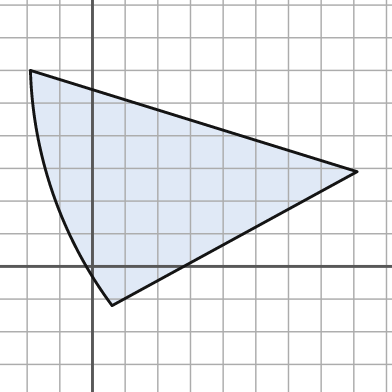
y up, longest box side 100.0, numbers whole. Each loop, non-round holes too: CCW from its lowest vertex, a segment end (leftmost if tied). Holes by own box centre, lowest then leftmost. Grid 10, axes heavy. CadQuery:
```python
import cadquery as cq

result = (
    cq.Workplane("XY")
    .moveTo(6.0, -12.0)
    .lineTo(81.0, 29.0)
    .lineTo(-19.0, 60.0)
    .threePointArc((-12.0, 22.0), (6.0, -12.0))
    .close()
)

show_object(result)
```